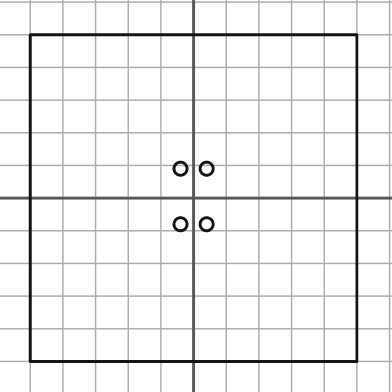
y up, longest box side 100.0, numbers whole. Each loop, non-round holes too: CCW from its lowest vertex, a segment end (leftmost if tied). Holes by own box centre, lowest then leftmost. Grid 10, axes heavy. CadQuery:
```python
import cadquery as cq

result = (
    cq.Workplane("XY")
    .moveTo(-50.0, -50.0)
    .lineTo(50.0, -50.0)
    .lineTo(50.0, 50.0)
    .lineTo(-50.0, 50.0)
    .close()
    .moveTo(-4.0, -8.0)
    .circle(2.0)
    .moveTo(4.0, -8.0)
    .circle(2.0)
    .moveTo(-4.0, 9.0)
    .circle(2.0)
    .moveTo(4.0, 9.0)
    .circle(2.0)
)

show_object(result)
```